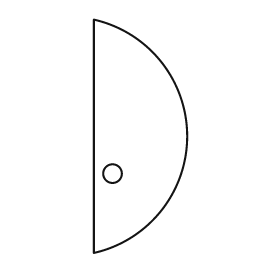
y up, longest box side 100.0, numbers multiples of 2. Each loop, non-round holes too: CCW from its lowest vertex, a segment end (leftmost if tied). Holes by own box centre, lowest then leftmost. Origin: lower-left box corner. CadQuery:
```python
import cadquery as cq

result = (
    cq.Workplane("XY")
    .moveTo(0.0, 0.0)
    .threePointArc((40.0, 50.0), (0.0, 100.0))
    .close()
    .moveTo(8.0, 34.0)
    .circle(4.0)
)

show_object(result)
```